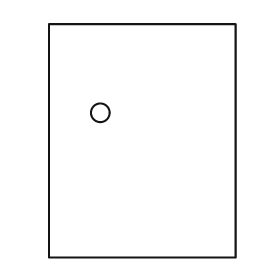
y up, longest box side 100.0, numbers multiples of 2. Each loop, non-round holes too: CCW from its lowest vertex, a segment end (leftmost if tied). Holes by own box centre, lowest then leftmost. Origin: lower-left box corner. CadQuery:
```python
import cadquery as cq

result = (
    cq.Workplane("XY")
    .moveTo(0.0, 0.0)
    .lineTo(80.0, 0.0)
    .lineTo(80.0, 100.0)
    .lineTo(0.0, 100.0)
    .close()
    .moveTo(22.0, 62.0)
    .circle(4.0)
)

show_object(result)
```